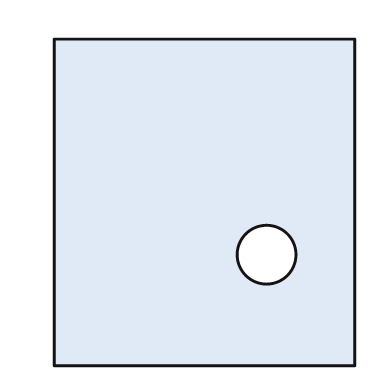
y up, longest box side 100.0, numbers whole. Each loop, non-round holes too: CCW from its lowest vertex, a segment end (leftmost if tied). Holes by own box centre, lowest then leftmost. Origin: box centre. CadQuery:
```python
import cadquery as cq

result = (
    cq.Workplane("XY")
    .moveTo(-46.0, -50.0)
    .lineTo(46.0, -50.0)
    .lineTo(46.0, 50.0)
    .lineTo(-46.0, 50.0)
    .close()
    .moveTo(19.0, -16.0)
    .circle(9.0)
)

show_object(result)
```